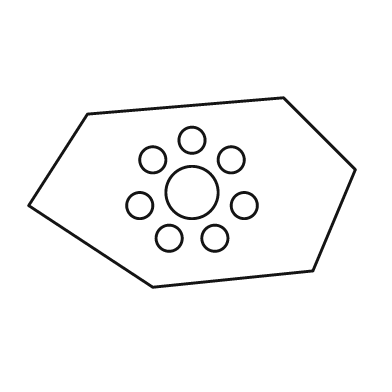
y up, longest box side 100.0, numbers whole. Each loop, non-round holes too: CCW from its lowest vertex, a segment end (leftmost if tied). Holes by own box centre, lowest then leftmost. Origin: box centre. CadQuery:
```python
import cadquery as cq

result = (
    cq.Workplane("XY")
    .moveTo(-12.0, -29.0)
    .lineTo(37.0, -24.0)
    .lineTo(50.0, 7.0)
    .lineTo(28.0, 29.0)
    .lineTo(-32.0, 24.0)
    .lineTo(-50.0, -4.0)
    .close()
    .moveTo(-7.0, -14.0)
    .circle(4.0)
    .moveTo(7.0, -14.0)
    .circle(4.0)
    .moveTo(-16.0, -4.0)
    .circle(4.0)
    .moveTo(16.0, -4.0)
    .circle(4.0)
    .moveTo(0.0, 0.0)
    .circle(8.0)
    .moveTo(-12.0, 10.0)
    .circle(4.0)
    .moveTo(12.0, 10.0)
    .circle(4.0)
    .moveTo(0.0, 16.0)
    .circle(4.0)
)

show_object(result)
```